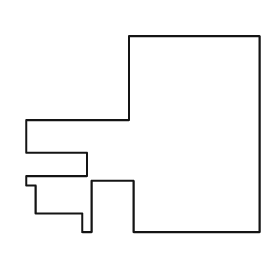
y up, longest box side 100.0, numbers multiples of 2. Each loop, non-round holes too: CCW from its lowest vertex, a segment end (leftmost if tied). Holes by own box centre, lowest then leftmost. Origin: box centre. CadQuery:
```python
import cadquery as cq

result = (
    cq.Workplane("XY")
    .moveTo(-26.0, -42.0)
    .lineTo(-22.0, -42.0)
    .lineTo(-22.0, -20.0)
    .lineTo(-4.0, -20.0)
    .lineTo(-4.0, -42.0)
    .lineTo(50.0, -42.0)
    .lineTo(50.0, 42.0)
    .lineTo(-6.0, 42.0)
    .lineTo(-6.0, 6.0)
    .lineTo(-50.0, 6.0)
    .lineTo(-50.0, -8.0)
    .lineTo(-24.0, -8.0)
    .lineTo(-24.0, -18.0)
    .lineTo(-50.0, -18.0)
    .lineTo(-50.0, -22.0)
    .lineTo(-46.0, -22.0)
    .lineTo(-46.0, -34.0)
    .lineTo(-26.0, -34.0)
    .close()
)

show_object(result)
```